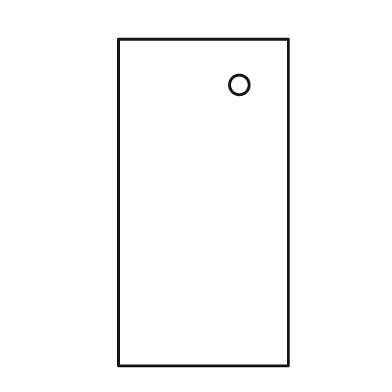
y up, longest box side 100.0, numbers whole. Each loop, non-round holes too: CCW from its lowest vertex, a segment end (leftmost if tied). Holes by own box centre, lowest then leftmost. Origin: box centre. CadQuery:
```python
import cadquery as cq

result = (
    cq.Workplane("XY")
    .moveTo(-26.0, -50.0)
    .lineTo(26.0, -50.0)
    .lineTo(26.0, 50.0)
    .lineTo(-26.0, 50.0)
    .close()
    .moveTo(11.0, 36.0)
    .circle(3.0)
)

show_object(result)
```